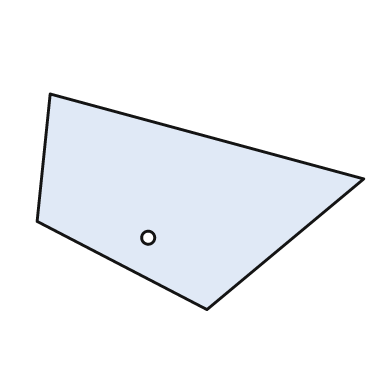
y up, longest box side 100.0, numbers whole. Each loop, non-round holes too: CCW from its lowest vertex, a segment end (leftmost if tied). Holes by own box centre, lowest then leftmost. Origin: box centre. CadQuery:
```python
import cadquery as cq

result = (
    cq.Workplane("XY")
    .moveTo(2.0, -33.0)
    .lineTo(50.0, 7.0)
    .lineTo(-46.0, 33.0)
    .lineTo(-50.0, -6.0)
    .close()
    .moveTo(-16.0, -11.0)
    .circle(2.0)
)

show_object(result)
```